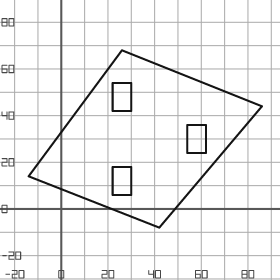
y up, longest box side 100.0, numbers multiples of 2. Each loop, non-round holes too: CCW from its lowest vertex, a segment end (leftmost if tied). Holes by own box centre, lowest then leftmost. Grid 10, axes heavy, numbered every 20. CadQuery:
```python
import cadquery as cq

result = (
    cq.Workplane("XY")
    .moveTo(42.0, -8.0)
    .lineTo(86.0, 44.0)
    .lineTo(26.0, 68.0)
    .lineTo(-14.0, 14.0)
    .close()
    .moveTo(22.0, 6.0)
    .lineTo(30.0, 6.0)
    .lineTo(30.0, 18.0)
    .lineTo(22.0, 18.0)
    .close()
    .moveTo(54.0, 24.0)
    .lineTo(62.0, 24.0)
    .lineTo(62.0, 36.0)
    .lineTo(54.0, 36.0)
    .close()
    .moveTo(22.0, 42.0)
    .lineTo(30.0, 42.0)
    .lineTo(30.0, 54.0)
    .lineTo(22.0, 54.0)
    .close()
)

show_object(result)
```